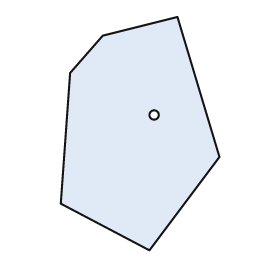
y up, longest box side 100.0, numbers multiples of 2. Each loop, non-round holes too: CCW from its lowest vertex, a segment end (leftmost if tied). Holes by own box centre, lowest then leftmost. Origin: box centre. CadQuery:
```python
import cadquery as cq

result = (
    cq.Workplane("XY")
    .moveTo(4.0, -50.0)
    .lineTo(34.0, -10.0)
    .lineTo(16.0, 50.0)
    .lineTo(-16.0, 42.0)
    .lineTo(-30.0, 26.0)
    .lineTo(-34.0, -30.0)
    .close()
    .moveTo(6.0, 8.0)
    .circle(2.0)
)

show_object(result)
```